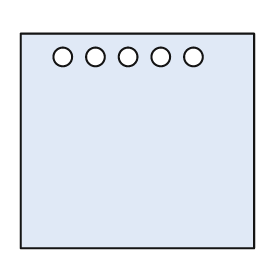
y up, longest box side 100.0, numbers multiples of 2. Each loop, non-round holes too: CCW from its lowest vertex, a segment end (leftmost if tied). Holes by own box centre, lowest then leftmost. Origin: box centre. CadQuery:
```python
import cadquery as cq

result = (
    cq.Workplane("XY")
    .moveTo(-50.0, -46.0)
    .lineTo(50.0, -46.0)
    .lineTo(50.0, 46.0)
    .lineTo(-50.0, 46.0)
    .close()
    .moveTo(-32.0, 36.0)
    .circle(4.0)
    .moveTo(-18.0, 36.0)
    .circle(4.0)
    .moveTo(-4.0, 36.0)
    .circle(4.0)
    .moveTo(10.0, 36.0)
    .circle(4.0)
    .moveTo(24.0, 36.0)
    .circle(4.0)
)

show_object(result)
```